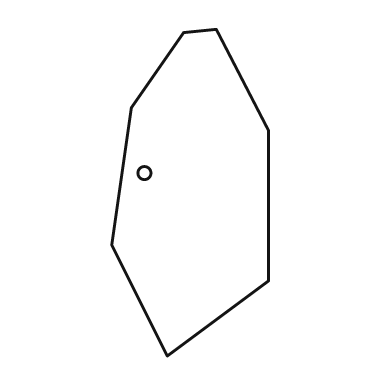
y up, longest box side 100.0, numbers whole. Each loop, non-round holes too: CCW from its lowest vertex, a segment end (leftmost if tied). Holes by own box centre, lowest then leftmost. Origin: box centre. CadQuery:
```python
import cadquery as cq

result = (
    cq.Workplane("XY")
    .moveTo(-7.0, -50.0)
    .lineTo(24.0, -27.0)
    .lineTo(24.0, 19.0)
    .lineTo(8.0, 50.0)
    .lineTo(-2.0, 49.0)
    .lineTo(-18.0, 26.0)
    .lineTo(-24.0, -16.0)
    .close()
    .moveTo(-14.0, 6.0)
    .circle(2.0)
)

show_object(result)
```